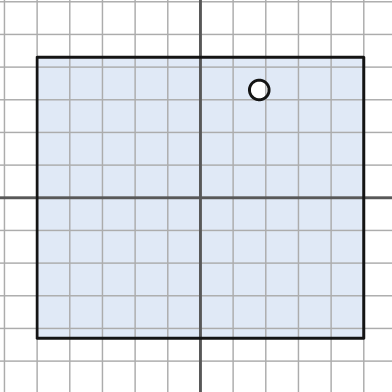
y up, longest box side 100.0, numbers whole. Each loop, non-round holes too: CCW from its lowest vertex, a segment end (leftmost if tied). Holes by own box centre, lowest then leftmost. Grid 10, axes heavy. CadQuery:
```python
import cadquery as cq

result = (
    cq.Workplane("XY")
    .moveTo(-50.0, -43.0)
    .lineTo(50.0, -43.0)
    .lineTo(50.0, 43.0)
    .lineTo(-50.0, 43.0)
    .close()
    .moveTo(18.0, 33.0)
    .circle(3.0)
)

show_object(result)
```